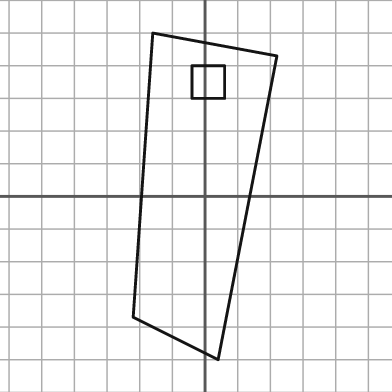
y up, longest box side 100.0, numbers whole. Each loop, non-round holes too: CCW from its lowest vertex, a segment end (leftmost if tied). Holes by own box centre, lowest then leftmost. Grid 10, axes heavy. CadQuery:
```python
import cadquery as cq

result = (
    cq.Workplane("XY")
    .moveTo(4.0, -50.0)
    .lineTo(22.0, 43.0)
    .lineTo(-16.0, 50.0)
    .lineTo(-22.0, -37.0)
    .close()
    .moveTo(-4.0, 30.0)
    .lineTo(6.0, 30.0)
    .lineTo(6.0, 40.0)
    .lineTo(-4.0, 40.0)
    .close()
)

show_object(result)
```